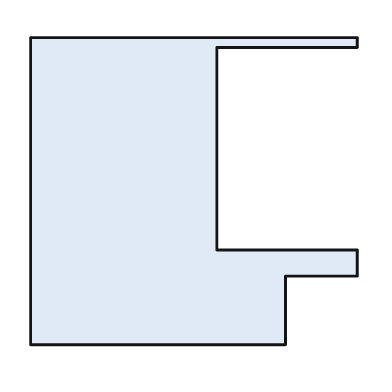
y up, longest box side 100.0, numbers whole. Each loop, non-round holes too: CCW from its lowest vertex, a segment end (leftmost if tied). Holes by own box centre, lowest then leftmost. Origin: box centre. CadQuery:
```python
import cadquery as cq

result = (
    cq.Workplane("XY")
    .moveTo(-50.0, -47.0)
    .lineTo(28.0, -47.0)
    .lineTo(28.0, -26.0)
    .lineTo(50.0, -26.0)
    .lineTo(50.0, -18.0)
    .lineTo(7.0, -18.0)
    .lineTo(7.0, 44.0)
    .lineTo(50.0, 44.0)
    .lineTo(50.0, 47.0)
    .lineTo(-50.0, 47.0)
    .close()
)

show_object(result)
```